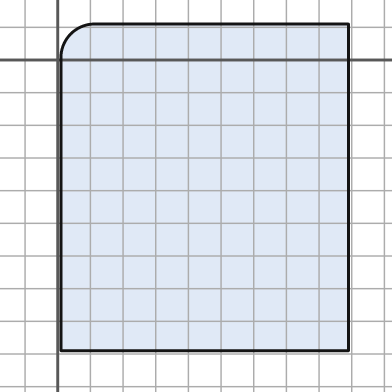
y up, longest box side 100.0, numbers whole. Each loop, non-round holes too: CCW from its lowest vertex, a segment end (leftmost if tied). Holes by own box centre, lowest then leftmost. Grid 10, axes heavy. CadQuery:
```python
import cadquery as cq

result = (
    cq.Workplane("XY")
    .moveTo(1.0, -89.0)
    .lineTo(89.0, -89.0)
    .lineTo(89.0, 11.0)
    .lineTo(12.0, 11.0)
    .threePointArc((4.0, 8.0), (1.0, 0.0))
    .close()
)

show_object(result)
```